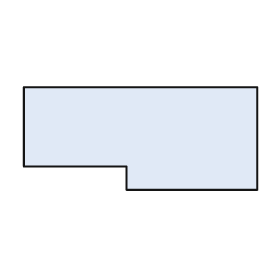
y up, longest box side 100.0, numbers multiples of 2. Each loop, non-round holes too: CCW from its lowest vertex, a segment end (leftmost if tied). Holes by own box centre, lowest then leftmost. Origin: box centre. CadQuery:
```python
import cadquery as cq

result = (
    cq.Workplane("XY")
    .moveTo(-6.0, -22.0)
    .lineTo(50.0, -22.0)
    .lineTo(50.0, 22.0)
    .lineTo(-50.0, 22.0)
    .lineTo(-50.0, -12.0)
    .lineTo(-6.0, -12.0)
    .close()
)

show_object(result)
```